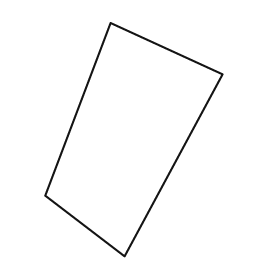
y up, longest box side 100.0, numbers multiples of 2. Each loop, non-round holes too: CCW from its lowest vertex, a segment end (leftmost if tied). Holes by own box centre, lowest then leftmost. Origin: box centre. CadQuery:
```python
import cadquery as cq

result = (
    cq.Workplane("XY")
    .moveTo(-4.0, -50.0)
    .lineTo(38.0, 28.0)
    .lineTo(-10.0, 50.0)
    .lineTo(-38.0, -24.0)
    .close()
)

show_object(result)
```